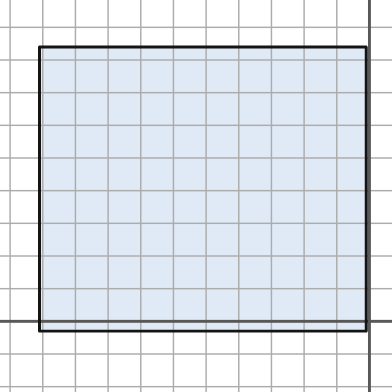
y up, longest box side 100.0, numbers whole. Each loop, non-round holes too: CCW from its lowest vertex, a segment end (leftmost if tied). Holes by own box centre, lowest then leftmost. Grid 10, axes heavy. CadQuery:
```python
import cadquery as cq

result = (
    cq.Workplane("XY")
    .moveTo(-101.0, -3.0)
    .lineTo(-1.0, -3.0)
    .lineTo(-1.0, 84.0)
    .lineTo(-101.0, 84.0)
    .close()
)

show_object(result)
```